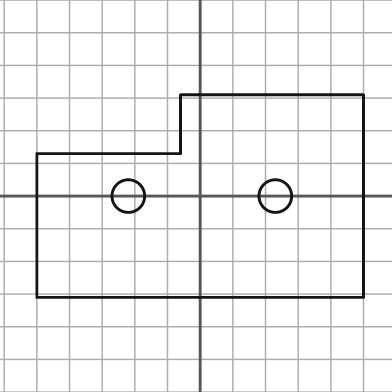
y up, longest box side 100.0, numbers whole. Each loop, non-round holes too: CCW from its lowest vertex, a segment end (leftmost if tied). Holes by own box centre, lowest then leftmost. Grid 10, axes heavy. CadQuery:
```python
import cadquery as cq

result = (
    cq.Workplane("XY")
    .moveTo(-50.0, -31.0)
    .lineTo(50.0, -31.0)
    .lineTo(50.0, 31.0)
    .lineTo(-6.0, 31.0)
    .lineTo(-6.0, 13.0)
    .lineTo(-50.0, 13.0)
    .close()
    .moveTo(-22.0, 0.0)
    .circle(5.0)
    .moveTo(23.0, 0.0)
    .circle(5.0)
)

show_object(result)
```